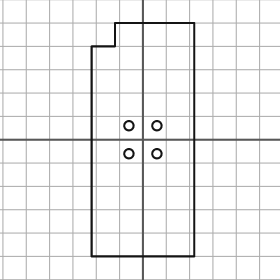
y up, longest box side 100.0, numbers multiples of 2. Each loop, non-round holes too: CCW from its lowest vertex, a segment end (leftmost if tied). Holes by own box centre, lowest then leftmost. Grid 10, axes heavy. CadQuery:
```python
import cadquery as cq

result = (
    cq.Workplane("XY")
    .moveTo(-22.0, -50.0)
    .lineTo(22.0, -50.0)
    .lineTo(22.0, 50.0)
    .lineTo(-12.0, 50.0)
    .lineTo(-12.0, 40.0)
    .lineTo(-22.0, 40.0)
    .close()
    .moveTo(-6.0, -6.0)
    .circle(2.0)
    .moveTo(6.0, -6.0)
    .circle(2.0)
    .moveTo(-6.0, 6.0)
    .circle(2.0)
    .moveTo(6.0, 6.0)
    .circle(2.0)
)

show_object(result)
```